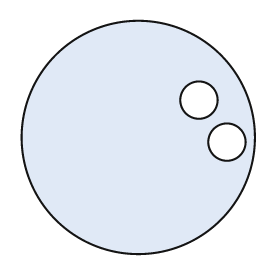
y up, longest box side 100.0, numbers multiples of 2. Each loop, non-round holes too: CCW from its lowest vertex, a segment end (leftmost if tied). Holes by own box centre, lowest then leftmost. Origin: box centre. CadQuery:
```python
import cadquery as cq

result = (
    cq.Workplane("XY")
    .moveTo(0.0, 0.0)
    .circle(50.0)
    .moveTo(38.0, -2.0)
    .circle(8.0)
    .moveTo(26.0, 16.0)
    .circle(8.0)
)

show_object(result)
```